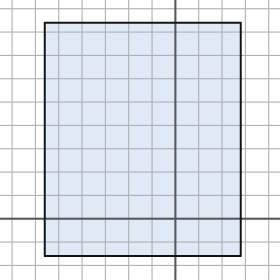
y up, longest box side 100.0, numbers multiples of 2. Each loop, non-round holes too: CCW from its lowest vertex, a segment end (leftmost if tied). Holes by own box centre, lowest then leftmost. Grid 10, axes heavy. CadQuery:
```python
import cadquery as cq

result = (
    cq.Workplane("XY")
    .moveTo(-56.0, -16.0)
    .lineTo(28.0, -16.0)
    .lineTo(28.0, 84.0)
    .lineTo(-56.0, 84.0)
    .close()
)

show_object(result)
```